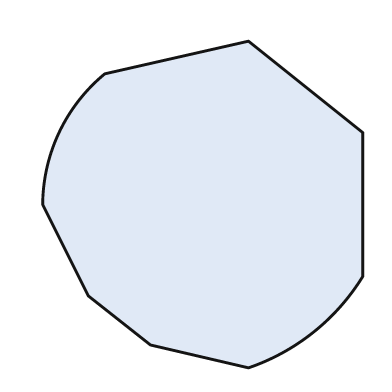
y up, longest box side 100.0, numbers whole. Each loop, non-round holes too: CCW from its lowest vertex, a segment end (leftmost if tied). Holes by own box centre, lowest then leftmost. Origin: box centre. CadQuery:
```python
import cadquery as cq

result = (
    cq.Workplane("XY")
    .moveTo(14.0, -50.0)
    .threePointArc((34.0, -39.0), (49.0, -22.0))
    .lineTo(49.0, 22.0)
    .lineTo(14.0, 50.0)
    .lineTo(-30.0, 40.0)
    .threePointArc((-44.0, 22.0), (-49.0, 0.0))
    .lineTo(-35.0, -28.0)
    .lineTo(-16.0, -43.0)
    .close()
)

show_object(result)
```